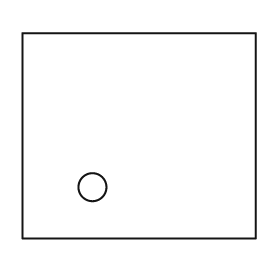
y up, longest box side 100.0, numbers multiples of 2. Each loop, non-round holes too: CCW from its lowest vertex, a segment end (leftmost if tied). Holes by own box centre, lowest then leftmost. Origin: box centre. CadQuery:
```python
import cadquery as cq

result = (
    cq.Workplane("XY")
    .moveTo(-50.0, -44.0)
    .lineTo(50.0, -44.0)
    .lineTo(50.0, 44.0)
    .lineTo(-50.0, 44.0)
    .close()
    .moveTo(-20.0, -22.0)
    .circle(6.0)
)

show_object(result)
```